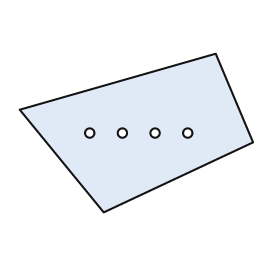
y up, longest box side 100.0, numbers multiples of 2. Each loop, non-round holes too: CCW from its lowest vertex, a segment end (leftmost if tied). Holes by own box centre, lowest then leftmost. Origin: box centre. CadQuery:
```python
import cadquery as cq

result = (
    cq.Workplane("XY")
    .moveTo(-14.0, -34.0)
    .lineTo(50.0, -4.0)
    .lineTo(34.0, 34.0)
    .lineTo(-50.0, 10.0)
    .close()
    .moveTo(-20.0, 0.0)
    .circle(2.0)
    .moveTo(-6.0, 0.0)
    .circle(2.0)
    .moveTo(8.0, 0.0)
    .circle(2.0)
    .moveTo(22.0, 0.0)
    .circle(2.0)
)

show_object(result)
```